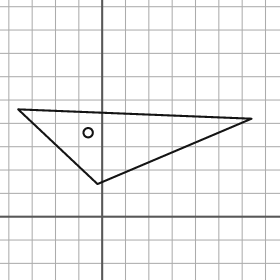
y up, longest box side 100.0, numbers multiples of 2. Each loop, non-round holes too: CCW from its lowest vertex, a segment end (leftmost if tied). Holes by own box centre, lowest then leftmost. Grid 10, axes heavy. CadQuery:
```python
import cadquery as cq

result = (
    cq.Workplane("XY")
    .moveTo(-2.0, 14.0)
    .lineTo(64.0, 42.0)
    .lineTo(-36.0, 46.0)
    .close()
    .moveTo(-6.0, 36.0)
    .circle(2.0)
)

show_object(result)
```